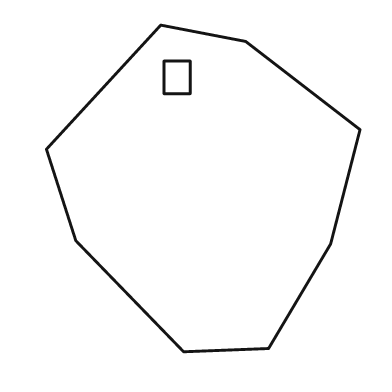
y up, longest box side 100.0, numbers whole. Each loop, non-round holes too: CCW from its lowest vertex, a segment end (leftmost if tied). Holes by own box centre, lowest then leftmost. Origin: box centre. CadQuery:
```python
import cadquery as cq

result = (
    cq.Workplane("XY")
    .moveTo(-6.0, -50.0)
    .lineTo(20.0, -49.0)
    .lineTo(39.0, -17.0)
    .lineTo(48.0, 18.0)
    .lineTo(13.0, 45.0)
    .lineTo(-13.0, 50.0)
    .lineTo(-48.0, 12.0)
    .lineTo(-39.0, -16.0)
    .close()
    .moveTo(-12.0, 29.0)
    .lineTo(-4.0, 29.0)
    .lineTo(-4.0, 39.0)
    .lineTo(-12.0, 39.0)
    .close()
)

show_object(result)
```